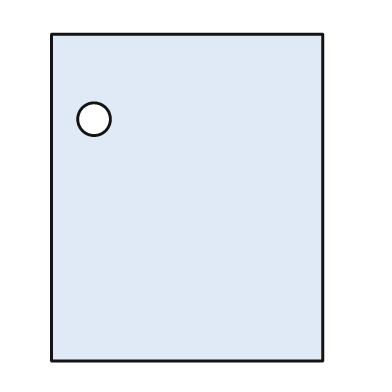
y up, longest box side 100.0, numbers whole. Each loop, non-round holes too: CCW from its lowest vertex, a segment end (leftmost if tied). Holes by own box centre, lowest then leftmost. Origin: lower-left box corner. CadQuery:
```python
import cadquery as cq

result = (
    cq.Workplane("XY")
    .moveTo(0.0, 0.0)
    .lineTo(83.0, 0.0)
    .lineTo(83.0, 100.0)
    .lineTo(0.0, 100.0)
    .close()
    .moveTo(13.0, 74.0)
    .circle(5.0)
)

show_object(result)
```